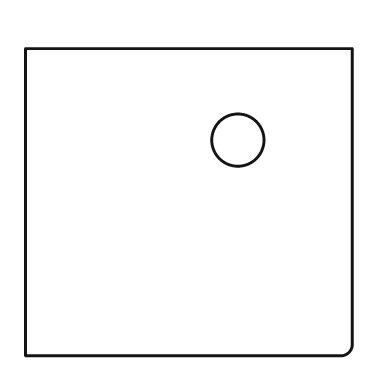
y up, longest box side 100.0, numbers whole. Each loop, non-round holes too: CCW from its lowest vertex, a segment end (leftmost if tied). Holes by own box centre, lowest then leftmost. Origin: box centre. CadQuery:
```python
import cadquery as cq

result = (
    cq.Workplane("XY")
    .moveTo(-50.0, -47.0)
    .lineTo(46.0, -47.0)
    .threePointArc((49.0, -46.0), (50.0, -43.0))
    .lineTo(50.0, 47.0)
    .lineTo(-50.0, 47.0)
    .close()
    .moveTo(15.0, 19.0)
    .circle(8.0)
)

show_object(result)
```